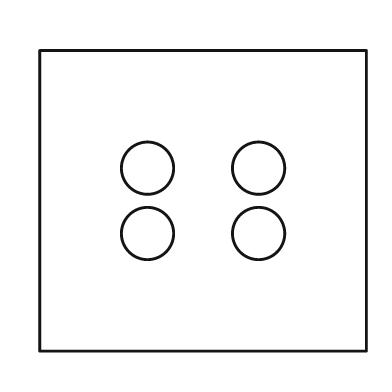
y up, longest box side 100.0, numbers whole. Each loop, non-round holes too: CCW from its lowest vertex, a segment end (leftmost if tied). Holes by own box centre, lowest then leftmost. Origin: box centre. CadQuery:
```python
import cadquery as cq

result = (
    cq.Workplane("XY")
    .moveTo(-50.0, -46.0)
    .lineTo(50.0, -46.0)
    .lineTo(50.0, 46.0)
    .lineTo(-50.0, 46.0)
    .close()
    .moveTo(-17.0, -10.0)
    .circle(8.0)
    .moveTo(17.0, -10.0)
    .circle(8.0)
    .moveTo(-17.0, 10.0)
    .circle(8.0)
    .moveTo(17.0, 10.0)
    .circle(8.0)
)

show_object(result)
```